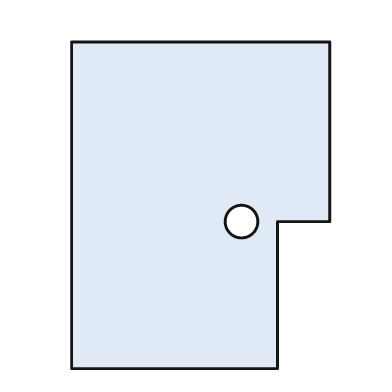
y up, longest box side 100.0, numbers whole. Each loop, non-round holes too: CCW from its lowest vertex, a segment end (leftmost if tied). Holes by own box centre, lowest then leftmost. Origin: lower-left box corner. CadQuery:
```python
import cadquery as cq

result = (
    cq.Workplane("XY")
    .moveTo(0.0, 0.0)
    .lineTo(63.0, 0.0)
    .lineTo(63.0, 45.0)
    .lineTo(79.0, 45.0)
    .lineTo(79.0, 100.0)
    .lineTo(0.0, 100.0)
    .close()
    .moveTo(52.0, 45.0)
    .circle(5.0)
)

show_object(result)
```